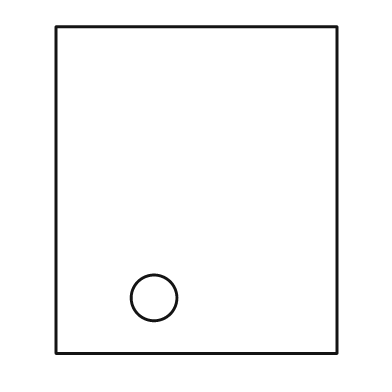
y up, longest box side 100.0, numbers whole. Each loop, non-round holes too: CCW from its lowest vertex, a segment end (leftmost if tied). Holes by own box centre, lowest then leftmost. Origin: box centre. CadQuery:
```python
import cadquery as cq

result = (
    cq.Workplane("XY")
    .moveTo(-43.0, -50.0)
    .lineTo(43.0, -50.0)
    .lineTo(43.0, 50.0)
    .lineTo(-43.0, 50.0)
    .close()
    .moveTo(-13.0, -33.0)
    .circle(7.0)
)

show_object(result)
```